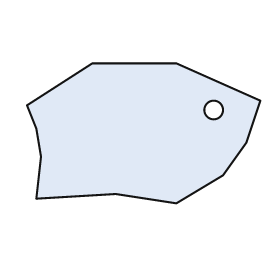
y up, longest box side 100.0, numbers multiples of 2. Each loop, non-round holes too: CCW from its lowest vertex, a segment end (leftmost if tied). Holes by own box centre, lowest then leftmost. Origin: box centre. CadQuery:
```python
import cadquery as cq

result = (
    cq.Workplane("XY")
    .moveTo(14.0, -30.0)
    .lineTo(34.0, -18.0)
    .lineTo(44.0, -4.0)
    .lineTo(50.0, 14.0)
    .lineTo(14.0, 30.0)
    .lineTo(-22.0, 30.0)
    .lineTo(-50.0, 12.0)
    .lineTo(-46.0, 2.0)
    .lineTo(-44.0, -10.0)
    .lineTo(-46.0, -28.0)
    .lineTo(-12.0, -26.0)
    .close()
    .moveTo(30.0, 10.0)
    .circle(4.0)
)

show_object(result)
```